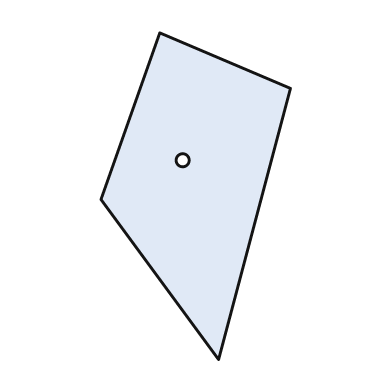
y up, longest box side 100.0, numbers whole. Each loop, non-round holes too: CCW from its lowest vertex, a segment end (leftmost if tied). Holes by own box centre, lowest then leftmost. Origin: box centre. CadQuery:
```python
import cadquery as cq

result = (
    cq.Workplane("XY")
    .moveTo(7.0, -50.0)
    .lineTo(29.0, 33.0)
    .lineTo(-11.0, 50.0)
    .lineTo(-29.0, -1.0)
    .close()
    .moveTo(-4.0, 11.0)
    .circle(2.0)
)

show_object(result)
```